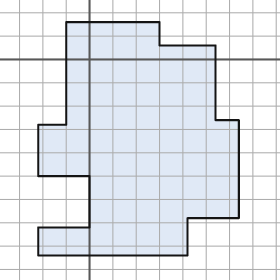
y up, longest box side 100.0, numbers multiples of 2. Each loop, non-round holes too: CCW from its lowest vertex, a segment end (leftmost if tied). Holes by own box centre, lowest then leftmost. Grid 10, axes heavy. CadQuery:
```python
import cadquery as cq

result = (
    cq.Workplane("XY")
    .moveTo(-22.0, -84.0)
    .lineTo(42.0, -84.0)
    .lineTo(42.0, -68.0)
    .lineTo(64.0, -68.0)
    .lineTo(64.0, -26.0)
    .lineTo(54.0, -26.0)
    .lineTo(54.0, 6.0)
    .lineTo(30.0, 6.0)
    .lineTo(30.0, 16.0)
    .lineTo(-10.0, 16.0)
    .lineTo(-10.0, -28.0)
    .lineTo(-22.0, -28.0)
    .lineTo(-22.0, -50.0)
    .lineTo(0.0, -50.0)
    .lineTo(0.0, -72.0)
    .lineTo(-22.0, -72.0)
    .close()
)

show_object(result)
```